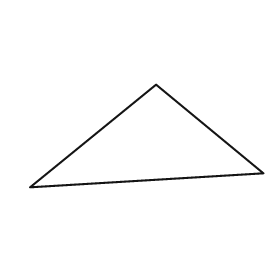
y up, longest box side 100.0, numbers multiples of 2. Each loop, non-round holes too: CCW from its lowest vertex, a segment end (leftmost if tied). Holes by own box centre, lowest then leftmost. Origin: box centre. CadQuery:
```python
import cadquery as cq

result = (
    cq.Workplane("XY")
    .moveTo(-50.0, -22.0)
    .lineTo(50.0, -16.0)
    .lineTo(4.0, 22.0)
    .close()
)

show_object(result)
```